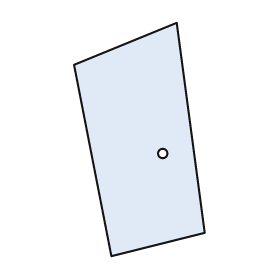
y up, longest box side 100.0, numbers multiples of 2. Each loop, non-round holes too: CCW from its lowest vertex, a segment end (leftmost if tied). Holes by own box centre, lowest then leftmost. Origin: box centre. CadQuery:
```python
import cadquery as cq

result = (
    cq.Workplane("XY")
    .moveTo(-12.0, -50.0)
    .lineTo(28.0, -40.0)
    .lineTo(16.0, 50.0)
    .lineTo(-28.0, 32.0)
    .close()
    .moveTo(10.0, -6.0)
    .circle(2.0)
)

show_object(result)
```